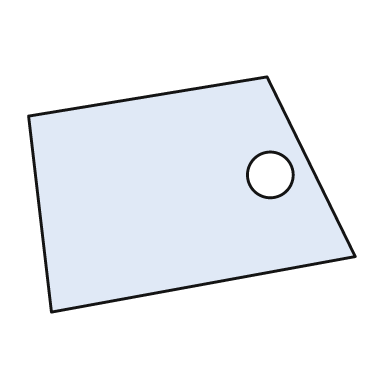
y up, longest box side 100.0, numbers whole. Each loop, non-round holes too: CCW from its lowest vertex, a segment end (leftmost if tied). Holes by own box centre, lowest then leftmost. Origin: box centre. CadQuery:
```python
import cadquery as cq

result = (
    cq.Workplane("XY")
    .moveTo(-43.0, -36.0)
    .lineTo(50.0, -19.0)
    .lineTo(23.0, 36.0)
    .lineTo(-50.0, 24.0)
    .close()
    .moveTo(24.0, 6.0)
    .circle(7.0)
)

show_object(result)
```